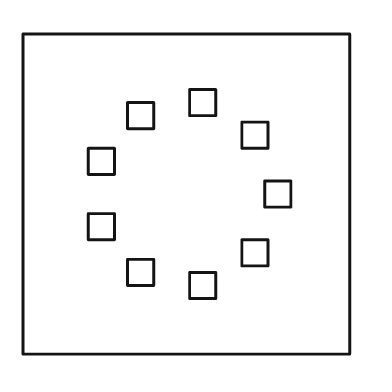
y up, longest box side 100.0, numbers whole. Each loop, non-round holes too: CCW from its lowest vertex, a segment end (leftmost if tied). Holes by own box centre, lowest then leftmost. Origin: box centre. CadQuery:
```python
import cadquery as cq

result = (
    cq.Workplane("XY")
    .moveTo(-50.0, -49.0)
    .lineTo(50.0, -49.0)
    .lineTo(50.0, 49.0)
    .lineTo(-50.0, 49.0)
    .close()
    .moveTo(1.0, -32.0)
    .lineTo(9.0, -32.0)
    .lineTo(9.0, -24.0)
    .lineTo(1.0, -24.0)
    .close()
    .moveTo(-18.0, -28.0)
    .lineTo(-10.0, -28.0)
    .lineTo(-10.0, -20.0)
    .lineTo(-18.0, -20.0)
    .close()
    .moveTo(17.0, -22.0)
    .lineTo(25.0, -22.0)
    .lineTo(25.0, -14.0)
    .lineTo(17.0, -14.0)
    .close()
    .moveTo(-30.0, -14.0)
    .lineTo(-22.0, -14.0)
    .lineTo(-22.0, -6.0)
    .lineTo(-30.0, -6.0)
    .close()
    .moveTo(24.0, -4.0)
    .lineTo(32.0, -4.0)
    .lineTo(32.0, 4.0)
    .lineTo(24.0, 4.0)
    .close()
    .moveTo(-30.0, 6.0)
    .lineTo(-22.0, 6.0)
    .lineTo(-22.0, 14.0)
    .lineTo(-30.0, 14.0)
    .close()
    .moveTo(17.0, 14.0)
    .lineTo(25.0, 14.0)
    .lineTo(25.0, 22.0)
    .lineTo(17.0, 22.0)
    .close()
    .moveTo(-18.0, 20.0)
    .lineTo(-10.0, 20.0)
    .lineTo(-10.0, 28.0)
    .lineTo(-18.0, 28.0)
    .close()
    .moveTo(1.0, 24.0)
    .lineTo(9.0, 24.0)
    .lineTo(9.0, 32.0)
    .lineTo(1.0, 32.0)
    .close()
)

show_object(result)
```